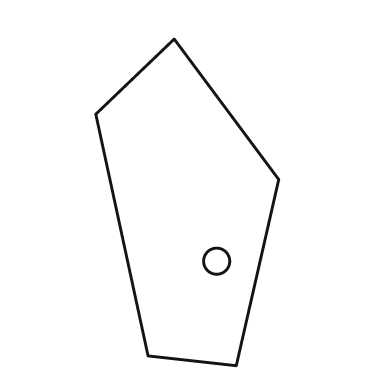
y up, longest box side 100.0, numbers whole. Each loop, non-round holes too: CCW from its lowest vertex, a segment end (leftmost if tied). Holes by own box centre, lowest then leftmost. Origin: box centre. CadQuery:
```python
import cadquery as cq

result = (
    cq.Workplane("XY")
    .moveTo(15.0, -50.0)
    .lineTo(28.0, 7.0)
    .lineTo(-4.0, 50.0)
    .lineTo(-28.0, 27.0)
    .lineTo(-12.0, -47.0)
    .close()
    .moveTo(9.0, -18.0)
    .circle(4.0)
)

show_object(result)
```